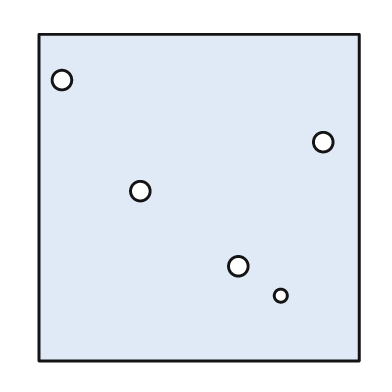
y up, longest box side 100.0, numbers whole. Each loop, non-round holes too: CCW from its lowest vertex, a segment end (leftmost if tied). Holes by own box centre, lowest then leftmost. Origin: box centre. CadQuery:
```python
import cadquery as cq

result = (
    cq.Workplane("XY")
    .moveTo(-49.0, -50.0)
    .lineTo(49.0, -50.0)
    .lineTo(49.0, 50.0)
    .lineTo(-49.0, 50.0)
    .close()
    .moveTo(25.0, -30.0)
    .circle(2.0)
    .moveTo(12.0, -21.0)
    .circle(3.0)
    .moveTo(-18.0, 2.0)
    .circle(3.0)
    .moveTo(38.0, 17.0)
    .circle(3.0)
    .moveTo(-42.0, 36.0)
    .circle(3.0)
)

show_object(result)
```